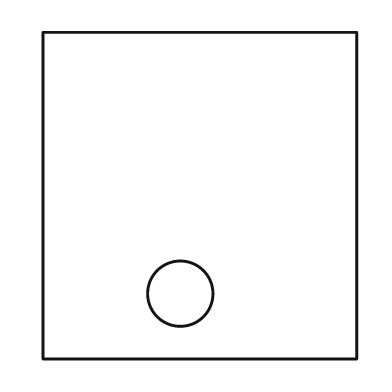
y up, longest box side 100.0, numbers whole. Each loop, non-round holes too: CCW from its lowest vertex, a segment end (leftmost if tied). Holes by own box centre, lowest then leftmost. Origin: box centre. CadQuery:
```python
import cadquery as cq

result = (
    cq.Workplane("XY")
    .moveTo(-48.0, -50.0)
    .lineTo(48.0, -50.0)
    .lineTo(48.0, 50.0)
    .lineTo(-48.0, 50.0)
    .close()
    .moveTo(-6.0, -30.0)
    .circle(10.0)
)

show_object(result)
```